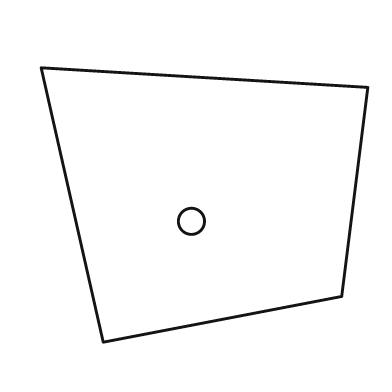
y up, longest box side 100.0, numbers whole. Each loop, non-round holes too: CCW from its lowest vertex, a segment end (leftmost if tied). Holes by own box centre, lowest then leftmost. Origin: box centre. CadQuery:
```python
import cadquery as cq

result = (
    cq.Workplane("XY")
    .moveTo(-31.0, -42.0)
    .lineTo(42.0, -28.0)
    .lineTo(50.0, 36.0)
    .lineTo(-50.0, 42.0)
    .close()
    .moveTo(-4.0, -5.0)
    .circle(4.0)
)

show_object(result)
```